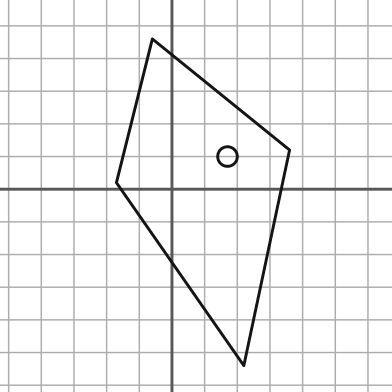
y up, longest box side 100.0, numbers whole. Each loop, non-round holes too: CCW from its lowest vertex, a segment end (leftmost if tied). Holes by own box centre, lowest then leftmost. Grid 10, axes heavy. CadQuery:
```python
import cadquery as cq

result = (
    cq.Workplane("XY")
    .moveTo(22.0, -54.0)
    .lineTo(36.0, 12.0)
    .lineTo(-6.0, 46.0)
    .lineTo(-17.0, 2.0)
    .close()
    .moveTo(17.0, 10.0)
    .circle(3.0)
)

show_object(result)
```